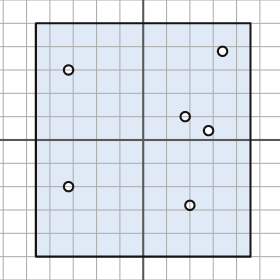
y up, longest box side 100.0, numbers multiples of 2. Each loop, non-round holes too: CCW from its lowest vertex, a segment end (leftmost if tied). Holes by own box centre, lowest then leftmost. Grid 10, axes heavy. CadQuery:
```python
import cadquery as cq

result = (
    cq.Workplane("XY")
    .moveTo(-46.0, -50.0)
    .lineTo(46.0, -50.0)
    .lineTo(46.0, 50.0)
    .lineTo(-46.0, 50.0)
    .close()
    .moveTo(20.0, -28.0)
    .circle(2.0)
    .moveTo(-32.0, -20.0)
    .circle(2.0)
    .moveTo(28.0, 4.0)
    .circle(2.0)
    .moveTo(18.0, 10.0)
    .circle(2.0)
    .moveTo(-32.0, 30.0)
    .circle(2.0)
    .moveTo(34.0, 38.0)
    .circle(2.0)
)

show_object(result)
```